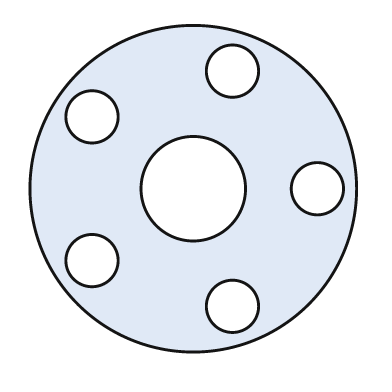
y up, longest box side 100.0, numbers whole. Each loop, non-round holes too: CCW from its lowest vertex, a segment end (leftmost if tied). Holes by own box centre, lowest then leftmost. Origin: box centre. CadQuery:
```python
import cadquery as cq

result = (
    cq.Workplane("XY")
    .moveTo(0.0, 0.0)
    .circle(50.0)
    .moveTo(12.0, -36.0)
    .circle(8.0)
    .moveTo(-31.0, -22.0)
    .circle(8.0)
    .moveTo(0.0, 0.0)
    .circle(16.0)
    .moveTo(38.0, 0.0)
    .circle(8.0)
    .moveTo(-31.0, 22.0)
    .circle(8.0)
    .moveTo(12.0, 36.0)
    .circle(8.0)
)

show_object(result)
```